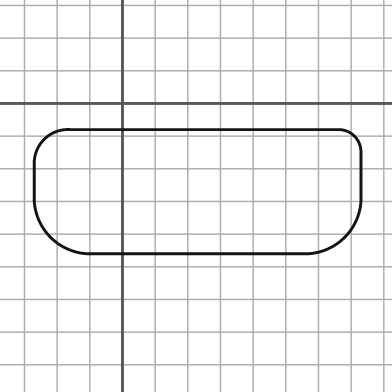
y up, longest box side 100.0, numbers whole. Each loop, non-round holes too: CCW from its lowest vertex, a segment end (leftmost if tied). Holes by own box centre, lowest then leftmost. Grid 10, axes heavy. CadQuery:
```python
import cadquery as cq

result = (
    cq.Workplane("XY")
    .moveTo(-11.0, -46.0)
    .lineTo(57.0, -46.0)
    .threePointArc((68.0, -41.0), (73.0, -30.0))
    .lineTo(73.0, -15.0)
    .threePointArc((71.0, -10.0), (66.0, -8.0))
    .lineTo(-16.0, -8.0)
    .threePointArc((-24.0, -11.0), (-27.0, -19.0))
    .lineTo(-27.0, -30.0)
    .threePointArc((-22.0, -41.0), (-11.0, -46.0))
    .close()
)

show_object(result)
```